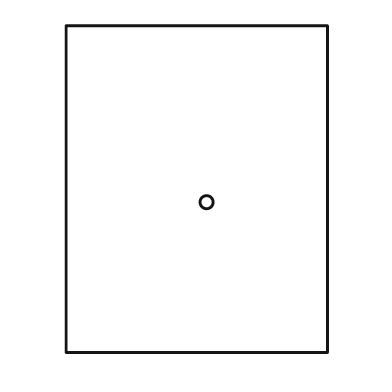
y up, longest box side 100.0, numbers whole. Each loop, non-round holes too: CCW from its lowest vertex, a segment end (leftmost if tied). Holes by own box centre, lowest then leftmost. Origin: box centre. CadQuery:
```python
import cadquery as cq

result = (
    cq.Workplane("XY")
    .moveTo(-40.0, -50.0)
    .lineTo(40.0, -50.0)
    .lineTo(40.0, 50.0)
    .lineTo(-40.0, 50.0)
    .close()
    .moveTo(3.0, -4.0)
    .circle(2.0)
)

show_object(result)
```